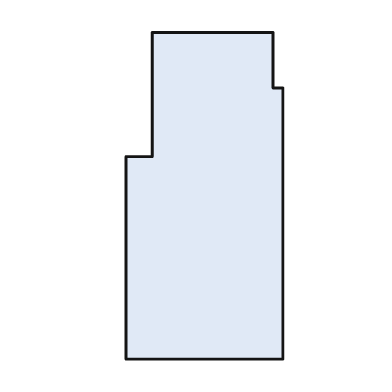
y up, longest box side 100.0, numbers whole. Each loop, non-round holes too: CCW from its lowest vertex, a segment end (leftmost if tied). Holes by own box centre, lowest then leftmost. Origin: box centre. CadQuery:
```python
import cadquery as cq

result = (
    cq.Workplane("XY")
    .moveTo(-24.0, -50.0)
    .lineTo(24.0, -50.0)
    .lineTo(24.0, 33.0)
    .lineTo(21.0, 33.0)
    .lineTo(21.0, 50.0)
    .lineTo(-16.0, 50.0)
    .lineTo(-16.0, 12.0)
    .lineTo(-24.0, 12.0)
    .close()
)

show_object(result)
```